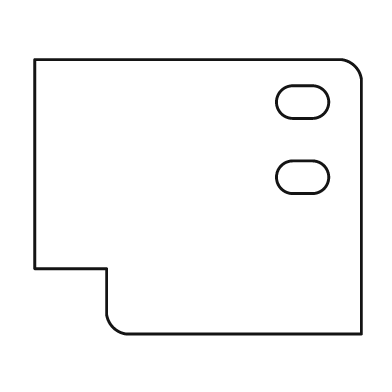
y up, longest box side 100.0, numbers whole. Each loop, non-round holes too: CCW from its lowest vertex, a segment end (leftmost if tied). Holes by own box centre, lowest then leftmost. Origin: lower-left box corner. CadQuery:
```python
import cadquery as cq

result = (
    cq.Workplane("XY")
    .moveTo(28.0, 0.0)
    .lineTo(100.0, 0.0)
    .lineTo(100.0, 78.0)
    .threePointArc((98.0, 82.0), (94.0, 84.0))
    .lineTo(0.0, 84.0)
    .lineTo(0.0, 20.0)
    .lineTo(22.0, 20.0)
    .lineTo(22.0, 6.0)
    .threePointArc((24.0, 2.0), (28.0, 0.0))
    .close()
    .moveTo(79.0, 43.0)
    .lineTo(85.0, 43.0)
    .threePointArc((90.0, 48.0), (85.0, 53.0))
    .lineTo(79.0, 53.0)
    .threePointArc((74.0, 48.0), (79.0, 43.0))
    .close()
    .moveTo(79.0, 66.0)
    .lineTo(85.0, 66.0)
    .threePointArc((90.0, 71.0), (85.0, 76.0))
    .lineTo(79.0, 76.0)
    .threePointArc((74.0, 71.0), (79.0, 66.0))
    .close()
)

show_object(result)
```